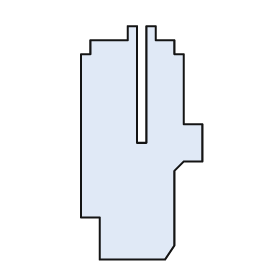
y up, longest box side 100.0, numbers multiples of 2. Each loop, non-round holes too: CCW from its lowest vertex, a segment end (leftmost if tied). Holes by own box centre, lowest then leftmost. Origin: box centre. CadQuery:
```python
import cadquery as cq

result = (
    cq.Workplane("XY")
    .moveTo(-18.0, -50.0)
    .lineTo(10.0, -50.0)
    .lineTo(14.0, -44.0)
    .lineTo(14.0, -12.0)
    .lineTo(18.0, -8.0)
    .lineTo(26.0, -8.0)
    .lineTo(26.0, 8.0)
    .lineTo(18.0, 8.0)
    .lineTo(18.0, 38.0)
    .lineTo(14.0, 38.0)
    .lineTo(14.0, 44.0)
    .lineTo(6.0, 44.0)
    .lineTo(6.0, 50.0)
    .lineTo(2.0, 50.0)
    .lineTo(2.0, 0.0)
    .lineTo(-2.0, 0.0)
    .lineTo(-2.0, 50.0)
    .lineTo(-6.0, 50.0)
    .lineTo(-6.0, 44.0)
    .lineTo(-22.0, 44.0)
    .lineTo(-22.0, 38.0)
    .lineTo(-26.0, 38.0)
    .lineTo(-26.0, -32.0)
    .lineTo(-18.0, -32.0)
    .close()
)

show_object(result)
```